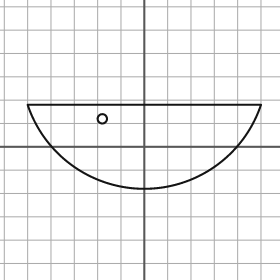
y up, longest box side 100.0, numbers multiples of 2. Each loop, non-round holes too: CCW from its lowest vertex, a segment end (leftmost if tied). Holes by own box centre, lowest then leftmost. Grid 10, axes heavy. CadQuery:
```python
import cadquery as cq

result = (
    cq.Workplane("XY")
    .moveTo(-50.0, 18.0)
    .threePointArc((0.0, -18.0), (50.0, 18.0))
    .close()
    .moveTo(-18.0, 12.0)
    .circle(2.0)
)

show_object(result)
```